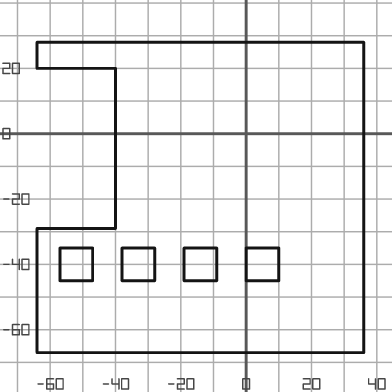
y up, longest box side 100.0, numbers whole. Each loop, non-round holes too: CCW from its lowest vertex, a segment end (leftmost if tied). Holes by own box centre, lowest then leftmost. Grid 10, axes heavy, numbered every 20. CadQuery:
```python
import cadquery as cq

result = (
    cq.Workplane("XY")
    .moveTo(-64.0, -67.0)
    .lineTo(36.0, -67.0)
    .lineTo(36.0, 28.0)
    .lineTo(-64.0, 28.0)
    .lineTo(-64.0, 20.0)
    .lineTo(-40.0, 20.0)
    .lineTo(-40.0, -29.0)
    .lineTo(-64.0, -29.0)
    .close()
    .moveTo(-57.0, -45.0)
    .lineTo(-47.0, -45.0)
    .lineTo(-47.0, -35.0)
    .lineTo(-57.0, -35.0)
    .close()
    .moveTo(-38.0, -45.0)
    .lineTo(-28.0, -45.0)
    .lineTo(-28.0, -35.0)
    .lineTo(-38.0, -35.0)
    .close()
    .moveTo(-19.0, -45.0)
    .lineTo(-9.0, -45.0)
    .lineTo(-9.0, -35.0)
    .lineTo(-19.0, -35.0)
    .close()
    .moveTo(0.0, -45.0)
    .lineTo(10.0, -45.0)
    .lineTo(10.0, -35.0)
    .lineTo(0.0, -35.0)
    .close()
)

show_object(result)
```